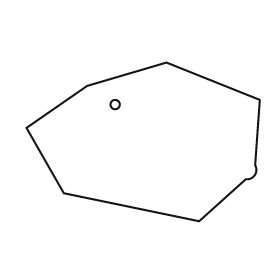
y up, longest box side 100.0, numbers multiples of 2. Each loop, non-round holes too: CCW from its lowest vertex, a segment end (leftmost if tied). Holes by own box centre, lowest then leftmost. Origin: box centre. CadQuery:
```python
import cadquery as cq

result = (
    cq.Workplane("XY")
    .moveTo(24.0, -34.0)
    .lineTo(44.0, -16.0)
    .threePointArc((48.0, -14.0), (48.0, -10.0))
    .lineTo(50.0, 18.0)
    .lineTo(10.0, 34.0)
    .lineTo(-24.0, 24.0)
    .lineTo(-50.0, 6.0)
    .lineTo(-34.0, -22.0)
    .close()
    .moveTo(-12.0, 16.0)
    .circle(2.0)
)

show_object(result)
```